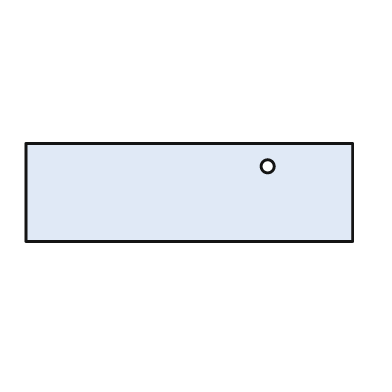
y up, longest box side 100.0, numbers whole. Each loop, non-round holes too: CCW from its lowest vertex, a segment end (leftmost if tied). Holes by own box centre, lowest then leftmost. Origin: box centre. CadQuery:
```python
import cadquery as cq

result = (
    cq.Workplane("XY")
    .moveTo(-50.0, -15.0)
    .lineTo(50.0, -15.0)
    .lineTo(50.0, 15.0)
    .lineTo(-50.0, 15.0)
    .close()
    .moveTo(24.0, 8.0)
    .circle(2.0)
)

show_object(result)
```